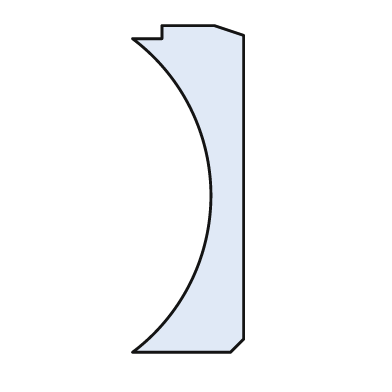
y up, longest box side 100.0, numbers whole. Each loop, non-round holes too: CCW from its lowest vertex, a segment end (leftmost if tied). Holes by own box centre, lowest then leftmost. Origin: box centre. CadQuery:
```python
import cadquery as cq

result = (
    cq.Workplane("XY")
    .moveTo(-17.0, -50.0)
    .lineTo(13.0, -50.0)
    .lineTo(17.0, -46.0)
    .lineTo(17.0, 47.0)
    .lineTo(8.0, 50.0)
    .lineTo(-8.0, 50.0)
    .lineTo(-8.0, 46.0)
    .lineTo(-17.0, 46.0)
    .threePointArc((7.0, -2.0), (-17.0, -50.0))
    .close()
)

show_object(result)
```